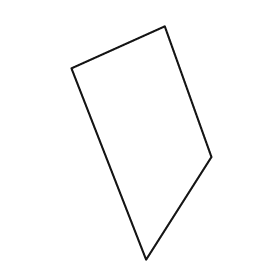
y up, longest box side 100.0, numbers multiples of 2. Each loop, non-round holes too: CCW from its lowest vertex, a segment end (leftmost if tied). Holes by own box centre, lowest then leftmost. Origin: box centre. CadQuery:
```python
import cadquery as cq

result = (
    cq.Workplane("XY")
    .moveTo(2.0, -50.0)
    .lineTo(30.0, -6.0)
    .lineTo(10.0, 50.0)
    .lineTo(-30.0, 32.0)
    .close()
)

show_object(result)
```